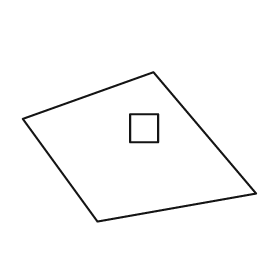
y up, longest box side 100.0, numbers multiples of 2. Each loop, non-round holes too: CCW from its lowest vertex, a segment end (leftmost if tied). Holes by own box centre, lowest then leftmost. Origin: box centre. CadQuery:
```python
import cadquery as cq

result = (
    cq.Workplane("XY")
    .moveTo(-18.0, -32.0)
    .lineTo(50.0, -20.0)
    .lineTo(6.0, 32.0)
    .lineTo(-50.0, 12.0)
    .close()
    .moveTo(-4.0, 2.0)
    .lineTo(8.0, 2.0)
    .lineTo(8.0, 14.0)
    .lineTo(-4.0, 14.0)
    .close()
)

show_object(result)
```